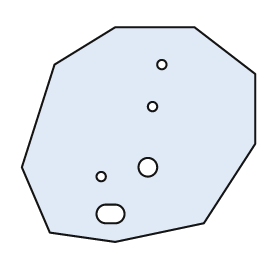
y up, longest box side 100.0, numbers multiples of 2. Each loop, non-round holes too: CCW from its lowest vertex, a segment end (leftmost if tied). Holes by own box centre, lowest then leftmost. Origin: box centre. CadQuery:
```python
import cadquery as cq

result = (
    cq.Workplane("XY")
    .moveTo(-10.0, -46.0)
    .lineTo(28.0, -38.0)
    .lineTo(50.0, -4.0)
    .lineTo(50.0, 26.0)
    .lineTo(24.0, 46.0)
    .lineTo(-10.0, 46.0)
    .lineTo(-36.0, 30.0)
    .lineTo(-50.0, -14.0)
    .lineTo(-38.0, -42.0)
    .close()
    .moveTo(-14.0, -38.0)
    .lineTo(-10.0, -38.0)
    .threePointArc((-6.0, -34.0), (-10.0, -30.0))
    .lineTo(-14.0, -30.0)
    .threePointArc((-18.0, -34.0), (-14.0, -38.0))
    .close()
    .moveTo(-16.0, -18.0)
    .circle(2.0)
    .moveTo(4.0, -14.0)
    .circle(4.0)
    .moveTo(6.0, 12.0)
    .circle(2.0)
    .moveTo(10.0, 30.0)
    .circle(2.0)
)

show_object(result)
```